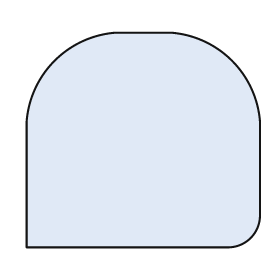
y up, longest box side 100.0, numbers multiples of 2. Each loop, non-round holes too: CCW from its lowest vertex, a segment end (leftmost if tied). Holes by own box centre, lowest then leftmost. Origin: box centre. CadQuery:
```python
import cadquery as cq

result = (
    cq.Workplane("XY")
    .moveTo(-50.0, -46.0)
    .lineTo(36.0, -46.0)
    .threePointArc((46.0, -42.0), (50.0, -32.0))
    .lineTo(50.0, 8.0)
    .threePointArc((38.0, 34.0), (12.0, 46.0))
    .lineTo(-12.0, 46.0)
    .threePointArc((-38.0, 34.0), (-50.0, 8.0))
    .close()
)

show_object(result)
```